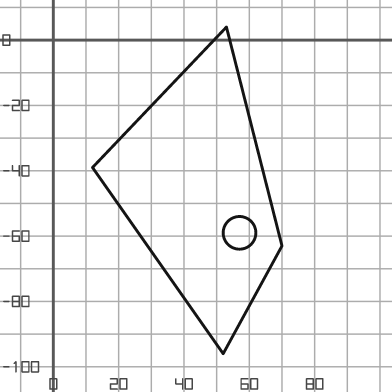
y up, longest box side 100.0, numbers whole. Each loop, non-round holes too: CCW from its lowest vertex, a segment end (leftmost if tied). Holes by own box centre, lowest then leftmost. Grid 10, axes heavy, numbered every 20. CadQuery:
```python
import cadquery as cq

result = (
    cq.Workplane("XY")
    .moveTo(52.0, -96.0)
    .lineTo(70.0, -63.0)
    .lineTo(53.0, 4.0)
    .lineTo(12.0, -39.0)
    .close()
    .moveTo(57.0, -59.0)
    .circle(5.0)
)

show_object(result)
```